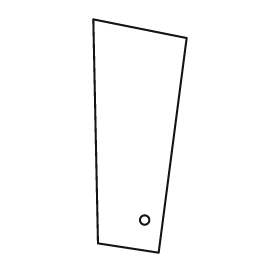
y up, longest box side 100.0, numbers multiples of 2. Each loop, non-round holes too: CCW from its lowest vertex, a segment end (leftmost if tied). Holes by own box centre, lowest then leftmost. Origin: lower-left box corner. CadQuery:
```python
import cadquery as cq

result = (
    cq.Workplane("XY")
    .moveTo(28.0, 0.0)
    .lineTo(40.0, 92.0)
    .lineTo(0.0, 100.0)
    .lineTo(2.0, 4.0)
    .close()
    .moveTo(22.0, 14.0)
    .circle(2.0)
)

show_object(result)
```